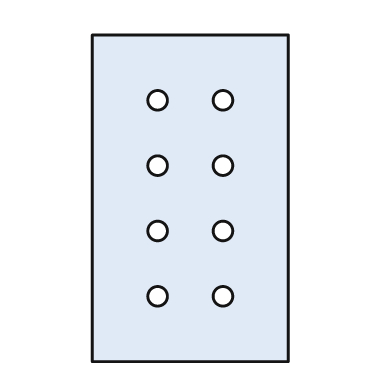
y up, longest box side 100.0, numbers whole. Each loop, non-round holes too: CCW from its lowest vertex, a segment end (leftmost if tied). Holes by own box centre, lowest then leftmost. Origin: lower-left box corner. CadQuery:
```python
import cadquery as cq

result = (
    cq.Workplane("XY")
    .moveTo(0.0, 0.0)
    .lineTo(60.0, 0.0)
    .lineTo(60.0, 100.0)
    .lineTo(0.0, 100.0)
    .close()
    .moveTo(20.0, 20.0)
    .circle(3.0)
    .moveTo(40.0, 20.0)
    .circle(3.0)
    .moveTo(20.0, 40.0)
    .circle(3.0)
    .moveTo(40.0, 40.0)
    .circle(3.0)
    .moveTo(20.0, 60.0)
    .circle(3.0)
    .moveTo(40.0, 60.0)
    .circle(3.0)
    .moveTo(20.0, 80.0)
    .circle(3.0)
    .moveTo(40.0, 80.0)
    .circle(3.0)
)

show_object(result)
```